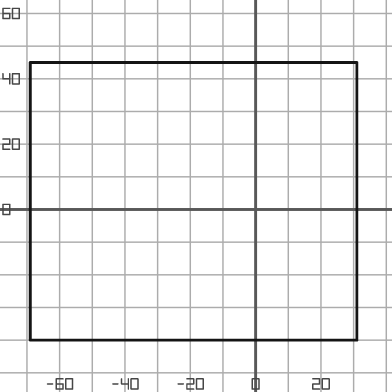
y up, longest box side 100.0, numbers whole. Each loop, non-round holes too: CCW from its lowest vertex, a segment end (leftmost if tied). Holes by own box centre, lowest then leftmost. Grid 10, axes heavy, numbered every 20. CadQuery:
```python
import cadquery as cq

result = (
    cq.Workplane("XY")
    .moveTo(-69.0, -40.0)
    .lineTo(31.0, -40.0)
    .lineTo(31.0, 45.0)
    .lineTo(-69.0, 45.0)
    .close()
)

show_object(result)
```